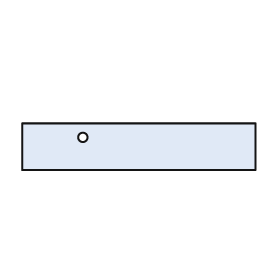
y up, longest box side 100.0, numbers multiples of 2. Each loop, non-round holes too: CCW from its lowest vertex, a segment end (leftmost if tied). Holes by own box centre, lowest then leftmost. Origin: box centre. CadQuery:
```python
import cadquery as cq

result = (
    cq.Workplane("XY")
    .moveTo(-50.0, -10.0)
    .lineTo(50.0, -10.0)
    .lineTo(50.0, 10.0)
    .lineTo(-50.0, 10.0)
    .close()
    .moveTo(-24.0, 4.0)
    .circle(2.0)
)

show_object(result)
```